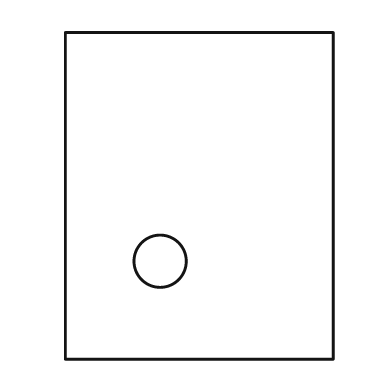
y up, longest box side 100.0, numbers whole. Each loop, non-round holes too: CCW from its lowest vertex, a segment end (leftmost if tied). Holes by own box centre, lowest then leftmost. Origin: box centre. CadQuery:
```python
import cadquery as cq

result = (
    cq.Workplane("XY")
    .moveTo(-41.0, -50.0)
    .lineTo(41.0, -50.0)
    .lineTo(41.0, 50.0)
    .lineTo(-41.0, 50.0)
    .close()
    .moveTo(-12.0, -20.0)
    .circle(8.0)
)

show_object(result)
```